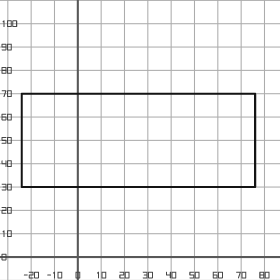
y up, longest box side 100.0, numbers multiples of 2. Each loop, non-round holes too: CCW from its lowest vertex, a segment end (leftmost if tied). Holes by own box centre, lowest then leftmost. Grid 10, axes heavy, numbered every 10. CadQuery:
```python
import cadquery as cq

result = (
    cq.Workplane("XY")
    .moveTo(-24.0, 30.0)
    .lineTo(76.0, 30.0)
    .lineTo(76.0, 70.0)
    .lineTo(-24.0, 70.0)
    .close()
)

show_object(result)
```